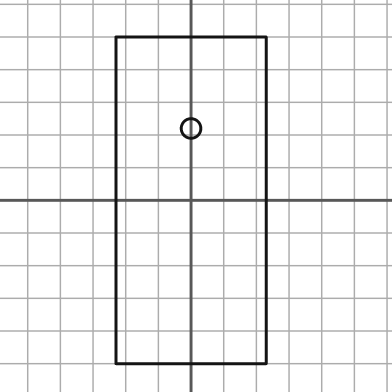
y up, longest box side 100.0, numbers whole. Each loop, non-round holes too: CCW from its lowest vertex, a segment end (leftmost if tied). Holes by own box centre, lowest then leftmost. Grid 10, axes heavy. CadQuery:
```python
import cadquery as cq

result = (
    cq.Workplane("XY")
    .moveTo(-23.0, -50.0)
    .lineTo(23.0, -50.0)
    .lineTo(23.0, 50.0)
    .lineTo(-23.0, 50.0)
    .close()
    .moveTo(0.0, 22.0)
    .circle(3.0)
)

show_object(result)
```